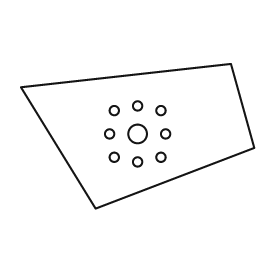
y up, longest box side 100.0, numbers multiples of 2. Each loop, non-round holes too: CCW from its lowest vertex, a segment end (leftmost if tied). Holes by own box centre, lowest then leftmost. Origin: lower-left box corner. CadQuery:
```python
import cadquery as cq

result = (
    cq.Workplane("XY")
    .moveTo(32.0, 0.0)
    .lineTo(100.0, 26.0)
    .lineTo(90.0, 62.0)
    .lineTo(0.0, 52.0)
    .close()
    .moveTo(50.0, 20.0)
    .circle(2.0)
    .moveTo(40.0, 22.0)
    .circle(2.0)
    .moveTo(60.0, 22.0)
    .circle(2.0)
    .moveTo(38.0, 32.0)
    .circle(2.0)
    .moveTo(50.0, 32.0)
    .circle(4.0)
    .moveTo(62.0, 32.0)
    .circle(2.0)
    .moveTo(40.0, 42.0)
    .circle(2.0)
    .moveTo(60.0, 42.0)
    .circle(2.0)
    .moveTo(50.0, 44.0)
    .circle(2.0)
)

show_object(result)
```